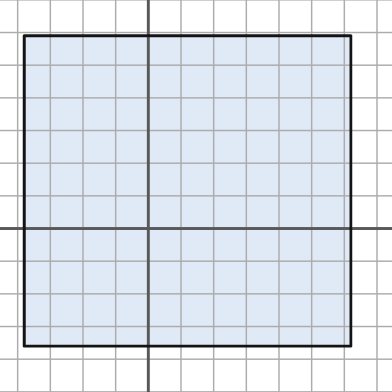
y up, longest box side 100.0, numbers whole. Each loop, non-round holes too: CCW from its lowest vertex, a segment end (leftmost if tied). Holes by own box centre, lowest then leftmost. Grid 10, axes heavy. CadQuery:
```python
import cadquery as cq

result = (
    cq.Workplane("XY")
    .moveTo(-38.0, -36.0)
    .lineTo(62.0, -36.0)
    .lineTo(62.0, 59.0)
    .lineTo(-38.0, 59.0)
    .close()
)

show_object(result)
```